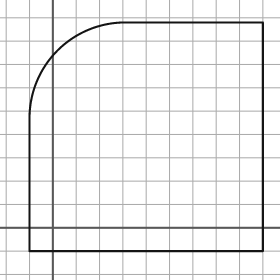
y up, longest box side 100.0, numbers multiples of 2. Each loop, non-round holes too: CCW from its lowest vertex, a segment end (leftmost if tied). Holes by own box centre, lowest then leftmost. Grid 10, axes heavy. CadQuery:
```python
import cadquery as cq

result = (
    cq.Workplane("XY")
    .moveTo(-10.0, -10.0)
    .lineTo(90.0, -10.0)
    .lineTo(90.0, 88.0)
    .lineTo(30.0, 88.0)
    .threePointArc((2.0, 76.0), (-10.0, 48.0))
    .close()
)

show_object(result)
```